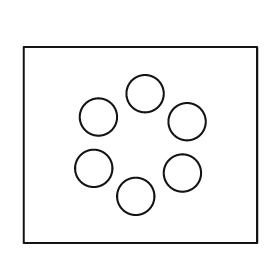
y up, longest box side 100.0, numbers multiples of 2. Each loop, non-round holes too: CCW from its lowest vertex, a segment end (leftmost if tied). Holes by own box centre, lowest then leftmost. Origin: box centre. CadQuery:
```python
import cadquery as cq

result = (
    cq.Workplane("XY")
    .moveTo(-50.0, -42.0)
    .lineTo(50.0, -42.0)
    .lineTo(50.0, 42.0)
    .lineTo(-50.0, 42.0)
    .close()
    .moveTo(-2.0, -22.0)
    .circle(8.0)
    .moveTo(18.0, -12.0)
    .circle(8.0)
    .moveTo(-20.0, -10.0)
    .circle(8.0)
    .moveTo(20.0, 10.0)
    .circle(8.0)
    .moveTo(-18.0, 12.0)
    .circle(8.0)
    .moveTo(2.0, 22.0)
    .circle(8.0)
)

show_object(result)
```